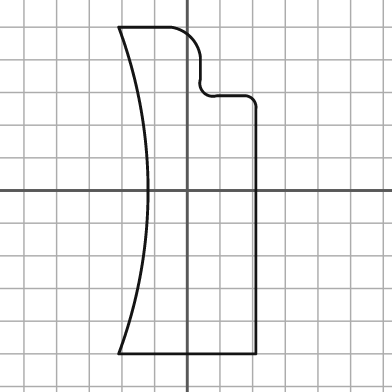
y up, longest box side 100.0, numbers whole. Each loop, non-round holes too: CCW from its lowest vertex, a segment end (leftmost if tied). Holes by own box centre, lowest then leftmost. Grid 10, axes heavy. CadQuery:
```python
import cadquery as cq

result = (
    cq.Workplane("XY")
    .moveTo(-21.0, -50.0)
    .lineTo(21.0, -50.0)
    .lineTo(21.0, 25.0)
    .threePointArc((20.0, 28.0), (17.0, 29.0))
    .lineTo(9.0, 29.0)
    .threePointArc((5.0, 30.0), (4.0, 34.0))
    .lineTo(4.0, 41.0)
    .threePointArc((1.0, 47.0), (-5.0, 50.0))
    .lineTo(-21.0, 50.0)
    .threePointArc((-12.0, 0.0), (-21.0, -50.0))
    .close()
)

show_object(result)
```